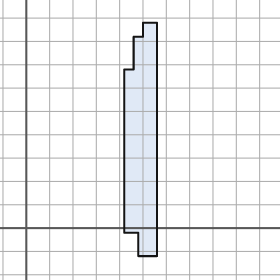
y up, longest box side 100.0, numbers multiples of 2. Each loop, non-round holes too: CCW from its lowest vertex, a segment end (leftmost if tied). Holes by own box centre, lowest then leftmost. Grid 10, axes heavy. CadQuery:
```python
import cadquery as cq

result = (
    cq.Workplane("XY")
    .moveTo(48.0, -12.0)
    .lineTo(56.0, -12.0)
    .lineTo(56.0, 88.0)
    .lineTo(50.0, 88.0)
    .lineTo(50.0, 82.0)
    .lineTo(46.0, 82.0)
    .lineTo(46.0, 68.0)
    .lineTo(42.0, 68.0)
    .lineTo(42.0, -2.0)
    .lineTo(48.0, -2.0)
    .close()
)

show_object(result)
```